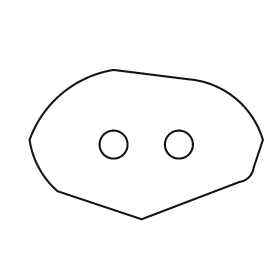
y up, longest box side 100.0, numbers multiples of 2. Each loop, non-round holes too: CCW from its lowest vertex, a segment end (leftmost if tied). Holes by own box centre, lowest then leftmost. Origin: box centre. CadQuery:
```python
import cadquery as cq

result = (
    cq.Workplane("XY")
    .moveTo(-2.0, -32.0)
    .lineTo(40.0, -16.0)
    .threePointArc((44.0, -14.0), (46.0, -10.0))
    .lineTo(50.0, 2.0)
    .threePointArc((38.0, 20.0), (18.0, 28.0))
    .lineTo(-14.0, 32.0)
    .threePointArc((-36.0, 22.0), (-50.0, 2.0))
    .threePointArc((-46.0, -10.0), (-38.0, -20.0))
    .close()
    .moveTo(-14.0, 0.0)
    .circle(6.0)
    .moveTo(14.0, 0.0)
    .circle(6.0)
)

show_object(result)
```